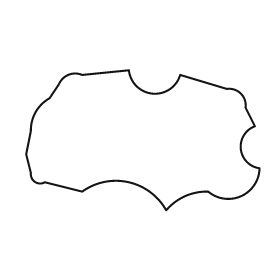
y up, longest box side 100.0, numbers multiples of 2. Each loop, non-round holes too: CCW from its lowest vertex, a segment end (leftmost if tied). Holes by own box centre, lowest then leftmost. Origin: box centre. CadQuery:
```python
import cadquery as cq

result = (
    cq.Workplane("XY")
    .moveTo(10.0, -30.0)
    .threePointArc((18.0, -24.0), (28.0, -22.0))
    .threePointArc((42.0, -24.0), (50.0, -12.0))
    .threePointArc((42.0, -4.0), (48.0, 6.0))
    .lineTo(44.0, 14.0)
    .threePointArc((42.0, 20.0), (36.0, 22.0))
    .lineTo(16.0, 28.0)
    .threePointArc((4.0, 20.0), (-6.0, 30.0))
    .lineTo(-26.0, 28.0)
    .threePointArc((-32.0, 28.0), (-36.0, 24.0))
    .lineTo(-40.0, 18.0)
    .threePointArc((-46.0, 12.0), (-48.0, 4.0))
    .lineTo(-50.0, -6.0)
    .lineTo(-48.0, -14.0)
    .threePointArc((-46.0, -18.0), (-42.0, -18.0))
    .lineTo(-26.0, -22.0)
    .threePointArc((-6.0, -18.0), (10.0, -30.0))
    .close()
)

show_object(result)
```